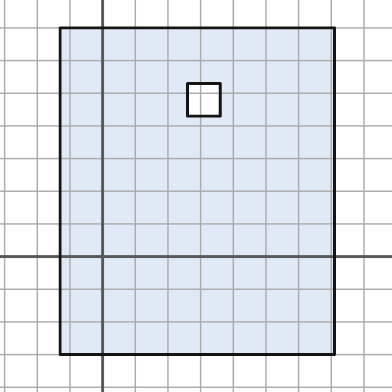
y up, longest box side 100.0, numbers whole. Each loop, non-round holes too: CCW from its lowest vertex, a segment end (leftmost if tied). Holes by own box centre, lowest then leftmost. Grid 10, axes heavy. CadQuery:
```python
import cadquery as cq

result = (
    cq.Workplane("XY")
    .moveTo(-13.0, -30.0)
    .lineTo(71.0, -30.0)
    .lineTo(71.0, 70.0)
    .lineTo(-13.0, 70.0)
    .close()
    .moveTo(26.0, 43.0)
    .lineTo(36.0, 43.0)
    .lineTo(36.0, 53.0)
    .lineTo(26.0, 53.0)
    .close()
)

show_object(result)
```